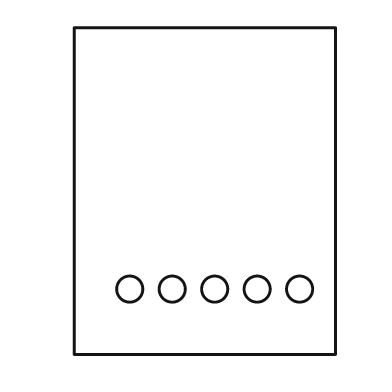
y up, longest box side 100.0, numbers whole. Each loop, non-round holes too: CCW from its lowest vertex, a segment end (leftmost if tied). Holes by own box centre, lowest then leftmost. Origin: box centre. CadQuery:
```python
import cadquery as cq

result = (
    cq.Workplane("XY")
    .moveTo(-40.0, -50.0)
    .lineTo(40.0, -50.0)
    .lineTo(40.0, 50.0)
    .lineTo(-40.0, 50.0)
    .close()
    .moveTo(-23.0, -30.0)
    .circle(4.0)
    .moveTo(-10.0, -30.0)
    .circle(4.0)
    .moveTo(3.0, -30.0)
    .circle(4.0)
    .moveTo(16.0, -30.0)
    .circle(4.0)
    .moveTo(29.0, -30.0)
    .circle(4.0)
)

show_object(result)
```